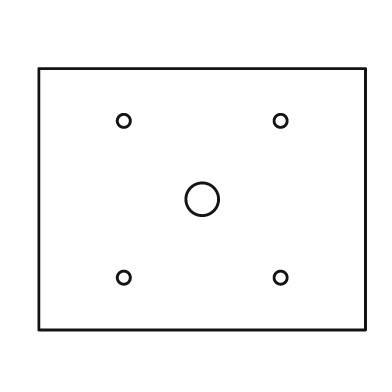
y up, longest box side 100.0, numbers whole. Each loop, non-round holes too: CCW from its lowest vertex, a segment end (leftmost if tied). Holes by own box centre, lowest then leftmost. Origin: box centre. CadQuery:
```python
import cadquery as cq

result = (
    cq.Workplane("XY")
    .moveTo(-50.0, -40.0)
    .lineTo(50.0, -40.0)
    .lineTo(50.0, 40.0)
    .lineTo(-50.0, 40.0)
    .close()
    .moveTo(-24.0, -24.0)
    .circle(2.0)
    .moveTo(24.0, -24.0)
    .circle(2.0)
    .moveTo(0.0, 0.0)
    .circle(5.0)
    .moveTo(-24.0, 24.0)
    .circle(2.0)
    .moveTo(24.0, 24.0)
    .circle(2.0)
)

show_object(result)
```